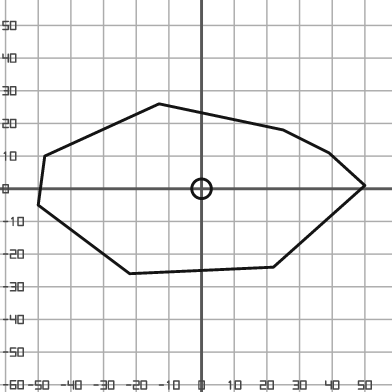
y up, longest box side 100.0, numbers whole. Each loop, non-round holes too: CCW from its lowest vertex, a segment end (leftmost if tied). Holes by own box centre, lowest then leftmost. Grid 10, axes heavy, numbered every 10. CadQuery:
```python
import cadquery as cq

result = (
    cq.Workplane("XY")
    .moveTo(-22.0, -26.0)
    .lineTo(22.0, -24.0)
    .lineTo(50.0, 1.0)
    .lineTo(39.0, 11.0)
    .lineTo(25.0, 18.0)
    .lineTo(-13.0, 26.0)
    .lineTo(-48.0, 10.0)
    .lineTo(-50.0, -5.0)
    .close()
    .moveTo(0.0, 0.0)
    .circle(3.0)
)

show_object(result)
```